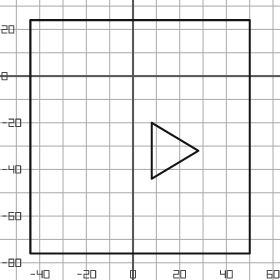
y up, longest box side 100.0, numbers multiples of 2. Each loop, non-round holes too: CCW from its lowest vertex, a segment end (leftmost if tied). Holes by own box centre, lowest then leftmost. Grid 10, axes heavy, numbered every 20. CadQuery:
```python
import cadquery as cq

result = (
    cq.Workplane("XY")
    .moveTo(-44.0, -76.0)
    .lineTo(50.0, -76.0)
    .lineTo(50.0, 24.0)
    .lineTo(-44.0, 24.0)
    .close()
    .moveTo(8.0, -44.0)
    .lineTo(28.0, -32.0)
    .lineTo(8.0, -20.0)
    .close()
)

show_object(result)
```